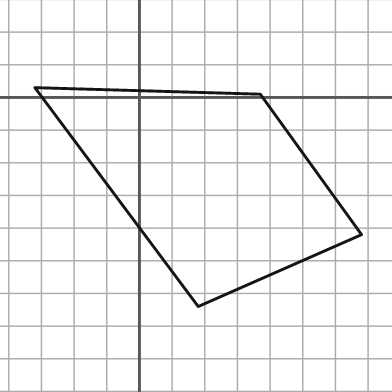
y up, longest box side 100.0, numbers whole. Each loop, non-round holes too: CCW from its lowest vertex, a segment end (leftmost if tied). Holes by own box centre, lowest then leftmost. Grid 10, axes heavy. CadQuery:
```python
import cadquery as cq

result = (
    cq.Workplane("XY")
    .moveTo(18.0, -64.0)
    .lineTo(68.0, -42.0)
    .lineTo(37.0, 1.0)
    .lineTo(-32.0, 3.0)
    .close()
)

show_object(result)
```